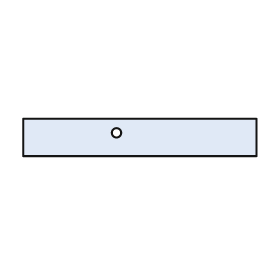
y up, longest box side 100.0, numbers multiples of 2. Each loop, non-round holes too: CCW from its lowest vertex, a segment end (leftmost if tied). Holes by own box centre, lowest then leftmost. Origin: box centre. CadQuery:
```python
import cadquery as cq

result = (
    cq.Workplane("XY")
    .moveTo(-50.0, -8.0)
    .lineTo(50.0, -8.0)
    .lineTo(50.0, 8.0)
    .lineTo(-50.0, 8.0)
    .close()
    .moveTo(-10.0, 2.0)
    .circle(2.0)
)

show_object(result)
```